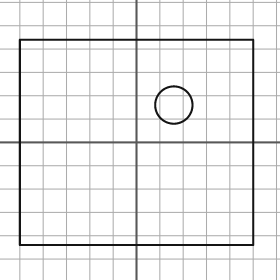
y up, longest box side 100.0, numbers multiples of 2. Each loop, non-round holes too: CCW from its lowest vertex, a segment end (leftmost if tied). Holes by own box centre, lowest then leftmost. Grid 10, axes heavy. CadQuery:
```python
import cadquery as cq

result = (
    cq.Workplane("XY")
    .moveTo(-50.0, -44.0)
    .lineTo(50.0, -44.0)
    .lineTo(50.0, 44.0)
    .lineTo(-50.0, 44.0)
    .close()
    .moveTo(16.0, 16.0)
    .circle(8.0)
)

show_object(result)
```